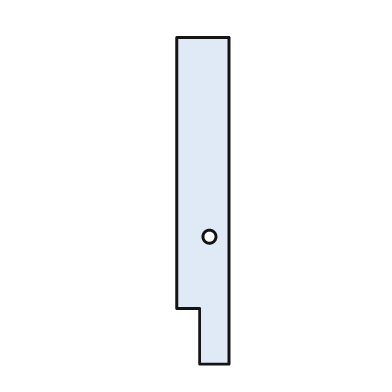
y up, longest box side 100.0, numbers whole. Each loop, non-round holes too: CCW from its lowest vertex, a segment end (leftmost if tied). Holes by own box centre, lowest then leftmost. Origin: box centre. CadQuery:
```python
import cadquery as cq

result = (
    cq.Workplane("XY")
    .moveTo(-1.0, -50.0)
    .lineTo(8.0, -50.0)
    .lineTo(8.0, 50.0)
    .lineTo(-8.0, 50.0)
    .lineTo(-8.0, -33.0)
    .lineTo(-1.0, -33.0)
    .close()
    .moveTo(2.0, -11.0)
    .circle(2.0)
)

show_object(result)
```